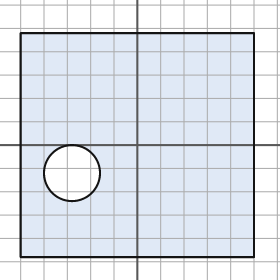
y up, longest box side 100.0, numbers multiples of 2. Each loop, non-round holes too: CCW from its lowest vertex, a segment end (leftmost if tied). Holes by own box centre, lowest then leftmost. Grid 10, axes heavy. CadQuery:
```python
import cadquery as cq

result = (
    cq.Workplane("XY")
    .moveTo(-50.0, -48.0)
    .lineTo(50.0, -48.0)
    .lineTo(50.0, 48.0)
    .lineTo(-50.0, 48.0)
    .close()
    .moveTo(-28.0, -12.0)
    .circle(12.0)
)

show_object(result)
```